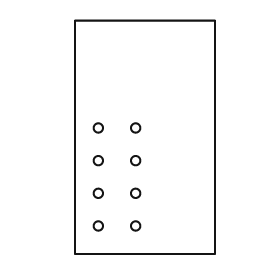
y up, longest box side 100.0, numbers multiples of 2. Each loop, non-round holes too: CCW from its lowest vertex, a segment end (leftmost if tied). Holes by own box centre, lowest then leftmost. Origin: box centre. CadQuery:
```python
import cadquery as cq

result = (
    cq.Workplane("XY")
    .moveTo(-30.0, -50.0)
    .lineTo(30.0, -50.0)
    .lineTo(30.0, 50.0)
    .lineTo(-30.0, 50.0)
    .close()
    .moveTo(-20.0, -38.0)
    .circle(2.0)
    .moveTo(-4.0, -38.0)
    .circle(2.0)
    .moveTo(-20.0, -24.0)
    .circle(2.0)
    .moveTo(-4.0, -24.0)
    .circle(2.0)
    .moveTo(-20.0, -10.0)
    .circle(2.0)
    .moveTo(-4.0, -10.0)
    .circle(2.0)
    .moveTo(-20.0, 4.0)
    .circle(2.0)
    .moveTo(-4.0, 4.0)
    .circle(2.0)
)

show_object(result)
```